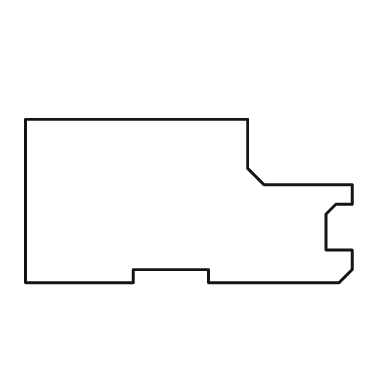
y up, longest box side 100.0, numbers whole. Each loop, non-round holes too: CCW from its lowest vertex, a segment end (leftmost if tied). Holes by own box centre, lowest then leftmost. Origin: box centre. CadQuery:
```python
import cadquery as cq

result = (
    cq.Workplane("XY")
    .moveTo(-50.0, -25.0)
    .lineTo(-17.0, -25.0)
    .lineTo(-17.0, -21.0)
    .lineTo(6.0, -21.0)
    .lineTo(6.0, -25.0)
    .lineTo(46.0, -25.0)
    .lineTo(50.0, -21.0)
    .lineTo(50.0, -15.0)
    .lineTo(42.0, -15.0)
    .lineTo(42.0, -4.0)
    .lineTo(45.0, -1.0)
    .lineTo(50.0, -1.0)
    .lineTo(50.0, 5.0)
    .lineTo(23.0, 5.0)
    .lineTo(18.0, 10.0)
    .lineTo(18.0, 25.0)
    .lineTo(-50.0, 25.0)
    .close()
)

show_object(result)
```